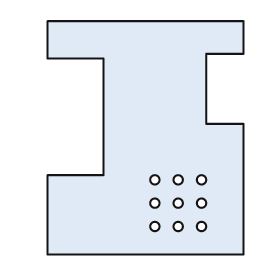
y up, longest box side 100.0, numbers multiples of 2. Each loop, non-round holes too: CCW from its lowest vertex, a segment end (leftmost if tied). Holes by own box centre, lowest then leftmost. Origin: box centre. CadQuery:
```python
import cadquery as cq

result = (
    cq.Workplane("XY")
    .moveTo(-42.0, -50.0)
    .lineTo(42.0, -50.0)
    .lineTo(42.0, 6.0)
    .lineTo(26.0, 6.0)
    .lineTo(26.0, 36.0)
    .lineTo(42.0, 36.0)
    .lineTo(42.0, 50.0)
    .lineTo(-42.0, 50.0)
    .lineTo(-42.0, 34.0)
    .lineTo(-18.0, 34.0)
    .lineTo(-18.0, -16.0)
    .lineTo(-42.0, -16.0)
    .close()
    .moveTo(4.0, -38.0)
    .circle(2.0)
    .moveTo(14.0, -38.0)
    .circle(2.0)
    .moveTo(24.0, -38.0)
    .circle(2.0)
    .moveTo(4.0, -28.0)
    .circle(2.0)
    .moveTo(14.0, -28.0)
    .circle(2.0)
    .moveTo(24.0, -28.0)
    .circle(2.0)
    .moveTo(4.0, -18.0)
    .circle(2.0)
    .moveTo(14.0, -18.0)
    .circle(2.0)
    .moveTo(24.0, -18.0)
    .circle(2.0)
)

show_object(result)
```